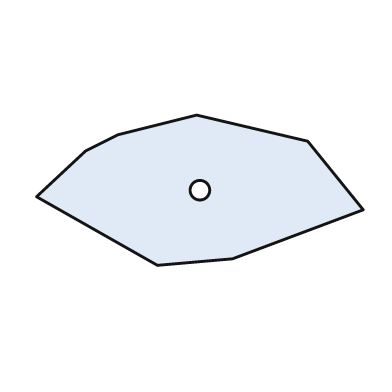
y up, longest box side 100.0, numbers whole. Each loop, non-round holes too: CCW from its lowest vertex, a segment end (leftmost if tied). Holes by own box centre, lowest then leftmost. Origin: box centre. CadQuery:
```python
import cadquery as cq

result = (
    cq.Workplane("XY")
    .moveTo(-13.0, -23.0)
    .lineTo(10.0, -21.0)
    .lineTo(50.0, -6.0)
    .lineTo(33.0, 15.0)
    .lineTo(-1.0, 23.0)
    .lineTo(-25.0, 17.0)
    .lineTo(-35.0, 12.0)
    .lineTo(-50.0, -2.0)
    .close()
    .moveTo(0.0, 0.0)
    .circle(3.0)
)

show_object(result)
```